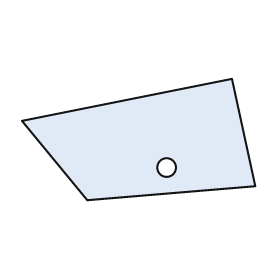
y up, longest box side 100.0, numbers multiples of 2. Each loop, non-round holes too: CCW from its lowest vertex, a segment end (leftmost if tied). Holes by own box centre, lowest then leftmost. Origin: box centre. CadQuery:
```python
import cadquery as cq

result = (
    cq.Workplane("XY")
    .moveTo(-22.0, -26.0)
    .lineTo(50.0, -20.0)
    .lineTo(40.0, 26.0)
    .lineTo(-50.0, 8.0)
    .close()
    .moveTo(12.0, -12.0)
    .circle(4.0)
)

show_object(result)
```